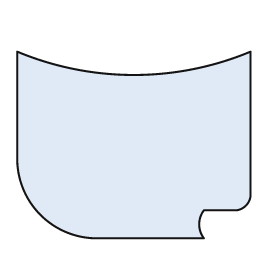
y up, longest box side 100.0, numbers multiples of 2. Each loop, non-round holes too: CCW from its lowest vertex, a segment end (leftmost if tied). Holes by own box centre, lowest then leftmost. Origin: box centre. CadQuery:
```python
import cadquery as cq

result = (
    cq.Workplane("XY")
    .moveTo(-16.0, -40.0)
    .lineTo(30.0, -40.0)
    .threePointArc((28.0, -34.0), (30.0, -28.0))
    .lineTo(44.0, -28.0)
    .threePointArc((48.0, -26.0), (50.0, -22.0))
    .lineTo(50.0, 40.0)
    .threePointArc((0.0, 30.0), (-50.0, 40.0))
    .lineTo(-50.0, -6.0)
    .threePointArc((-40.0, -30.0), (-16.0, -40.0))
    .close()
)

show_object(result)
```